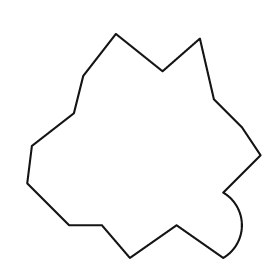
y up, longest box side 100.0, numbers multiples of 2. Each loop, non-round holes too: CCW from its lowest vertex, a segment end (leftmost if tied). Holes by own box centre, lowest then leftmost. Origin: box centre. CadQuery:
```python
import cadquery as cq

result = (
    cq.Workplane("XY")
    .moveTo(-6.0, -48.0)
    .lineTo(14.0, -34.0)
    .lineTo(34.0, -48.0)
    .threePointArc((42.0, -34.0), (34.0, -20.0))
    .lineTo(50.0, -4.0)
    .lineTo(42.0, 8.0)
    .lineTo(30.0, 20.0)
    .lineTo(24.0, 46.0)
    .lineTo(8.0, 32.0)
    .lineTo(-12.0, 48.0)
    .lineTo(-26.0, 30.0)
    .lineTo(-30.0, 14.0)
    .lineTo(-48.0, 0.0)
    .lineTo(-50.0, -16.0)
    .lineTo(-32.0, -34.0)
    .lineTo(-18.0, -34.0)
    .close()
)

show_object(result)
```